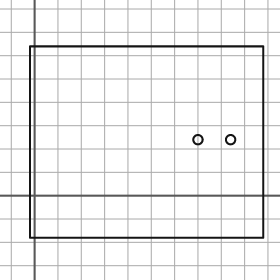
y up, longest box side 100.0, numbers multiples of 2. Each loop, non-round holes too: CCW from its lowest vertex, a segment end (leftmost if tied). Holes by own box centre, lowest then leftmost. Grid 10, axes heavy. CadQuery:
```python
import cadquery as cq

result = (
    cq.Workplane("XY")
    .moveTo(-2.0, -18.0)
    .lineTo(98.0, -18.0)
    .lineTo(98.0, 64.0)
    .lineTo(-2.0, 64.0)
    .close()
    .moveTo(70.0, 24.0)
    .circle(2.0)
    .moveTo(84.0, 24.0)
    .circle(2.0)
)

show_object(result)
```